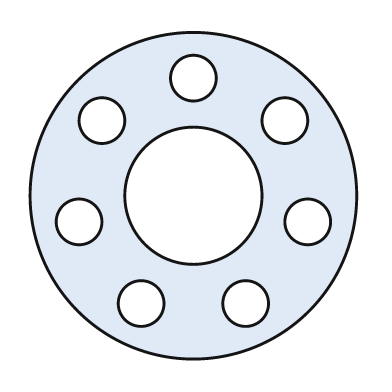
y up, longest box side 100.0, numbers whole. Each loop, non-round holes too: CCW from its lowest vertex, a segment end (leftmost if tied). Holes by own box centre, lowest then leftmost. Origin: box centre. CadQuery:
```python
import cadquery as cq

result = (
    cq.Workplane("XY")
    .moveTo(0.0, 0.0)
    .circle(50.0)
    .moveTo(-16.0, -33.0)
    .circle(7.0)
    .moveTo(16.0, -33.0)
    .circle(7.0)
    .moveTo(-35.0, -8.0)
    .circle(7.0)
    .moveTo(35.0, -8.0)
    .circle(7.0)
    .moveTo(0.0, 0.0)
    .circle(21.0)
    .moveTo(-28.0, 23.0)
    .circle(7.0)
    .moveTo(28.0, 23.0)
    .circle(7.0)
    .moveTo(0.0, 36.0)
    .circle(7.0)
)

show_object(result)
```